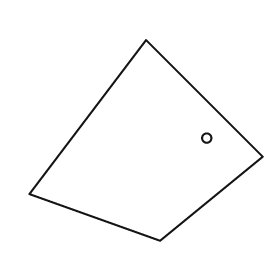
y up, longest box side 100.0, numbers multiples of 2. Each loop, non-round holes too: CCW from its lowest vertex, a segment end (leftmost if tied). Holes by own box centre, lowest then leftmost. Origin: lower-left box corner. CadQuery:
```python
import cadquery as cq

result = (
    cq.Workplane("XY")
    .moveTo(56.0, 0.0)
    .lineTo(100.0, 36.0)
    .lineTo(50.0, 86.0)
    .lineTo(0.0, 20.0)
    .close()
    .moveTo(76.0, 44.0)
    .circle(2.0)
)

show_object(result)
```